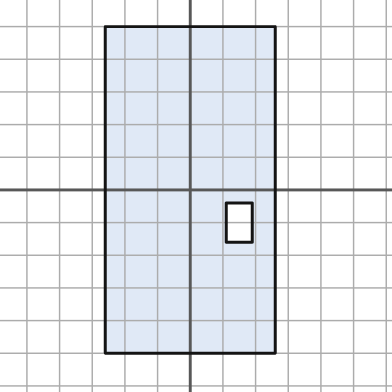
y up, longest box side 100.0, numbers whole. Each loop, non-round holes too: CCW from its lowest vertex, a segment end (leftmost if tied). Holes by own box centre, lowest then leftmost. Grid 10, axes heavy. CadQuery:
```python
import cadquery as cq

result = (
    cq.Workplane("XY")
    .moveTo(-26.0, -50.0)
    .lineTo(26.0, -50.0)
    .lineTo(26.0, 50.0)
    .lineTo(-26.0, 50.0)
    .close()
    .moveTo(11.0, -16.0)
    .lineTo(19.0, -16.0)
    .lineTo(19.0, -4.0)
    .lineTo(11.0, -4.0)
    .close()
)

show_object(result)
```